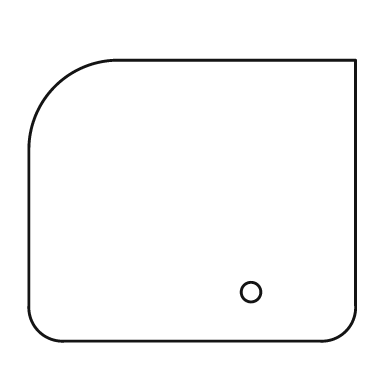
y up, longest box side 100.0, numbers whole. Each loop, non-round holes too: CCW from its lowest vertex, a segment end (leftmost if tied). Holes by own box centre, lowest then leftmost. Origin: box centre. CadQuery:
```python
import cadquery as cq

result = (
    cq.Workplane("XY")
    .moveTo(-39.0, -43.0)
    .lineTo(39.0, -43.0)
    .threePointArc((47.0, -40.0), (50.0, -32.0))
    .lineTo(50.0, 43.0)
    .lineTo(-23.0, 43.0)
    .threePointArc((-42.0, 35.0), (-50.0, 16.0))
    .lineTo(-50.0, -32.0)
    .threePointArc((-47.0, -40.0), (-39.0, -43.0))
    .close()
    .moveTo(18.0, -28.0)
    .circle(3.0)
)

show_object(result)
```